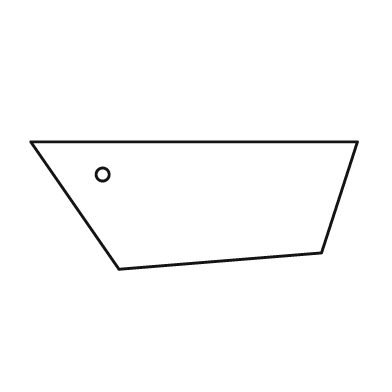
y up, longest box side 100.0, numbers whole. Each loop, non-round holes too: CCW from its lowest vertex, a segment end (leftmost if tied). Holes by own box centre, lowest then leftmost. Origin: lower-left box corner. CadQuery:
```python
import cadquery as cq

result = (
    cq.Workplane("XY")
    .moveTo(27.0, 0.0)
    .lineTo(89.0, 5.0)
    .lineTo(100.0, 39.0)
    .lineTo(0.0, 39.0)
    .close()
    .moveTo(22.0, 29.0)
    .circle(2.0)
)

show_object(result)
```